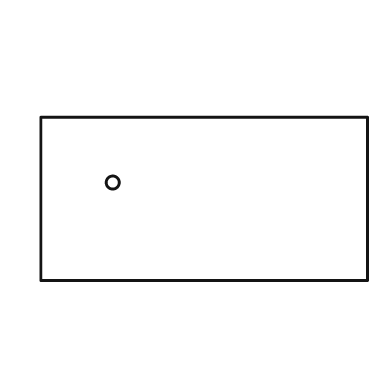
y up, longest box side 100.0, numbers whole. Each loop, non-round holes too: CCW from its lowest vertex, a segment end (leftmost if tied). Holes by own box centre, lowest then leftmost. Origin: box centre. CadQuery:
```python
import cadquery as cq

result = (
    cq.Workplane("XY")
    .moveTo(-50.0, -25.0)
    .lineTo(50.0, -25.0)
    .lineTo(50.0, 25.0)
    .lineTo(-50.0, 25.0)
    .close()
    .moveTo(-28.0, 5.0)
    .circle(2.0)
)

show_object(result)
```